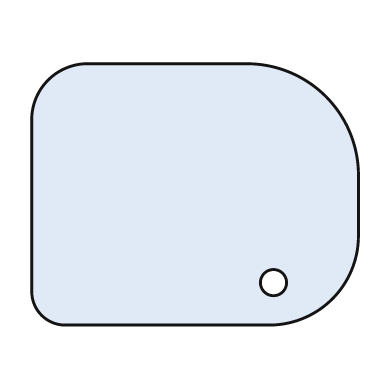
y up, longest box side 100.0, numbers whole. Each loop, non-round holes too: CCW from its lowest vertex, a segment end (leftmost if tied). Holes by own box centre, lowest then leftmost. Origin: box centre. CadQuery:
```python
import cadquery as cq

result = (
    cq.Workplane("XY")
    .moveTo(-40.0, -40.0)
    .lineTo(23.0, -40.0)
    .threePointArc((42.0, -32.0), (50.0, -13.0))
    .lineTo(50.0, 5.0)
    .threePointArc((40.0, 30.0), (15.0, 40.0))
    .lineTo(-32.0, 40.0)
    .threePointArc((-45.0, 35.0), (-50.0, 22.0))
    .lineTo(-50.0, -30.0)
    .threePointArc((-47.0, -37.0), (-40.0, -40.0))
    .close()
    .moveTo(24.0, -27.0)
    .circle(4.0)
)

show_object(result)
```